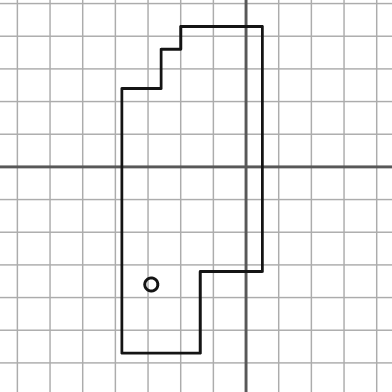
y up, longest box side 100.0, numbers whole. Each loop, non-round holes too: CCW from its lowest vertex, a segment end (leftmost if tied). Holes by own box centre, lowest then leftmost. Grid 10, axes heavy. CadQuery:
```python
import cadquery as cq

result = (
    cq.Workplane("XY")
    .moveTo(-38.0, -57.0)
    .lineTo(-14.0, -57.0)
    .lineTo(-14.0, -32.0)
    .lineTo(5.0, -32.0)
    .lineTo(5.0, 43.0)
    .lineTo(-20.0, 43.0)
    .lineTo(-20.0, 36.0)
    .lineTo(-26.0, 36.0)
    .lineTo(-26.0, 24.0)
    .lineTo(-38.0, 24.0)
    .close()
    .moveTo(-29.0, -36.0)
    .circle(2.0)
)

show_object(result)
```